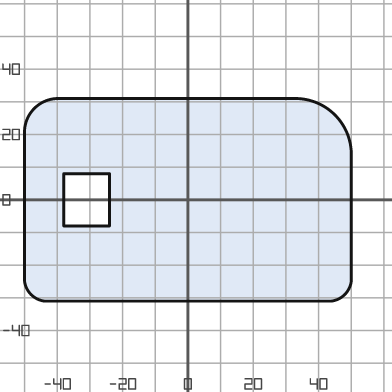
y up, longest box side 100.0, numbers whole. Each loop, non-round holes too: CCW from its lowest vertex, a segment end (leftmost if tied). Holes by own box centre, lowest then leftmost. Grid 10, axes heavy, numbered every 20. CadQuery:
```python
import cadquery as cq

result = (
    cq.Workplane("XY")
    .moveTo(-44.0, -31.0)
    .lineTo(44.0, -31.0)
    .threePointArc((48.0, -29.0), (50.0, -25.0))
    .lineTo(50.0, 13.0)
    .threePointArc((45.0, 26.0), (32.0, 31.0))
    .lineTo(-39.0, 31.0)
    .threePointArc((-47.0, 28.0), (-50.0, 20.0))
    .lineTo(-50.0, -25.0)
    .threePointArc((-48.0, -29.0), (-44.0, -31.0))
    .close()
    .moveTo(-38.0, -8.0)
    .lineTo(-24.0, -8.0)
    .lineTo(-24.0, 8.0)
    .lineTo(-38.0, 8.0)
    .close()
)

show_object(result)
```